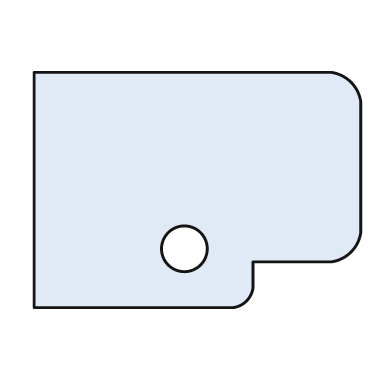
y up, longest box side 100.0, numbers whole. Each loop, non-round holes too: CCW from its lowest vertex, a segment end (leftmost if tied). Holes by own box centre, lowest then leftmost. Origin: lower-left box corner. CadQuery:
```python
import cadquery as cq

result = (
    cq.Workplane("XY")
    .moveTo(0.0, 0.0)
    .lineTo(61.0, 0.0)
    .threePointArc((65.0, 2.0), (67.0, 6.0))
    .lineTo(67.0, 14.0)
    .lineTo(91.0, 14.0)
    .threePointArc((97.0, 17.0), (100.0, 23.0))
    .lineTo(100.0, 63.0)
    .threePointArc((97.0, 69.0), (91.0, 72.0))
    .lineTo(0.0, 72.0)
    .close()
    .moveTo(46.0, 18.0)
    .circle(7.0)
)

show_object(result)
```